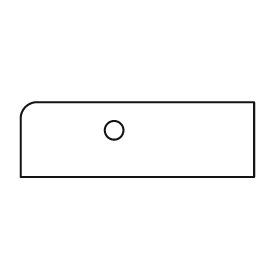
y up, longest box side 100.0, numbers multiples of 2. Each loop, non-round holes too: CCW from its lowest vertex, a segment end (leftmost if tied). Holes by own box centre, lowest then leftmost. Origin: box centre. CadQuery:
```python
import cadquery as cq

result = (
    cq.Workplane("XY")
    .moveTo(-50.0, -16.0)
    .lineTo(50.0, -16.0)
    .lineTo(50.0, 16.0)
    .lineTo(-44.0, 16.0)
    .threePointArc((-48.0, 14.0), (-50.0, 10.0))
    .close()
    .moveTo(-10.0, 4.0)
    .circle(4.0)
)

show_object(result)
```